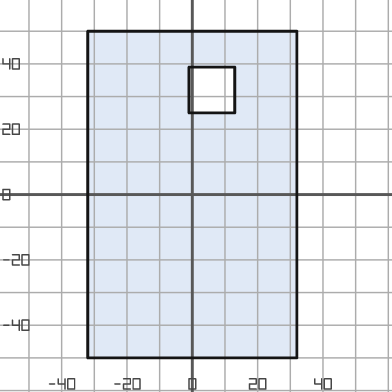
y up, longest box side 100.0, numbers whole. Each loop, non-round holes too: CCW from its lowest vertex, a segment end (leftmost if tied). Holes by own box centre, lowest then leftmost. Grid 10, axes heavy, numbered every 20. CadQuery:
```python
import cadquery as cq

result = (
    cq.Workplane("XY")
    .moveTo(-32.0, -50.0)
    .lineTo(32.0, -50.0)
    .lineTo(32.0, 50.0)
    .lineTo(-32.0, 50.0)
    .close()
    .moveTo(-1.0, 25.0)
    .lineTo(13.0, 25.0)
    .lineTo(13.0, 39.0)
    .lineTo(-1.0, 39.0)
    .close()
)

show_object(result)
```